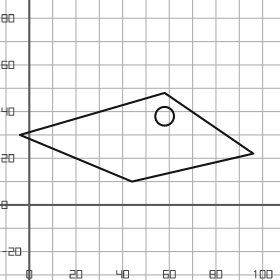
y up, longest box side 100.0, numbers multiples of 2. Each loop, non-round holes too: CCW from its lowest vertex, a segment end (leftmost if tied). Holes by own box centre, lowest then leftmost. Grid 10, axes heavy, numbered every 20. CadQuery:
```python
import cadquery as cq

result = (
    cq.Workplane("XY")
    .moveTo(44.0, 10.0)
    .lineTo(96.0, 22.0)
    .lineTo(58.0, 48.0)
    .lineTo(-4.0, 30.0)
    .close()
    .moveTo(58.0, 38.0)
    .circle(4.0)
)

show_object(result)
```